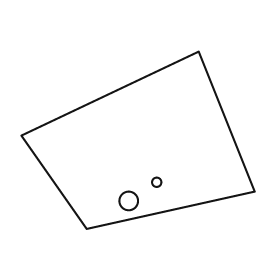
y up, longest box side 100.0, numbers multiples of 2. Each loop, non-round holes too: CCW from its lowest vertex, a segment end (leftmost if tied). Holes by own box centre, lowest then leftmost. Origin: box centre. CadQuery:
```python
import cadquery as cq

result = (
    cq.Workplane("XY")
    .moveTo(-22.0, -38.0)
    .lineTo(50.0, -22.0)
    .lineTo(26.0, 38.0)
    .lineTo(-50.0, 2.0)
    .close()
    .moveTo(-4.0, -26.0)
    .circle(4.0)
    .moveTo(8.0, -18.0)
    .circle(2.0)
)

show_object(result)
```